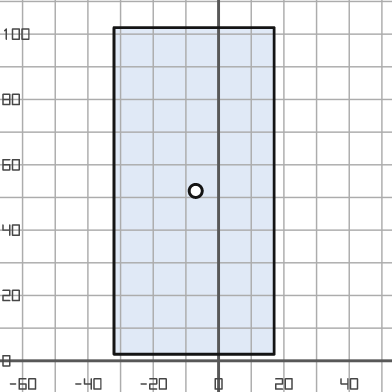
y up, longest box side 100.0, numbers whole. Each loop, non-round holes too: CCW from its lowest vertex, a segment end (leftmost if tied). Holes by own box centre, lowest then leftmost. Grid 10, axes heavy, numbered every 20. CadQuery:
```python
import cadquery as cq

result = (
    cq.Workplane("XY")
    .moveTo(-32.0, 2.0)
    .lineTo(17.0, 2.0)
    .lineTo(17.0, 102.0)
    .lineTo(-32.0, 102.0)
    .close()
    .moveTo(-7.0, 52.0)
    .circle(2.0)
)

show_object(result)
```